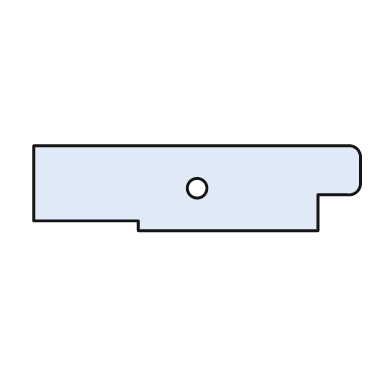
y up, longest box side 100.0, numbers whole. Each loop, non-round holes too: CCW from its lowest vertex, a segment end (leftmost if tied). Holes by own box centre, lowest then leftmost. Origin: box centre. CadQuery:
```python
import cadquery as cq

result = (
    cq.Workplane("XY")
    .moveTo(-18.0, -13.0)
    .lineTo(37.0, -13.0)
    .lineTo(37.0, -2.0)
    .lineTo(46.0, -2.0)
    .threePointArc((49.0, -1.0), (50.0, 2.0))
    .lineTo(50.0, 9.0)
    .threePointArc((49.0, 12.0), (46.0, 13.0))
    .lineTo(-50.0, 13.0)
    .lineTo(-50.0, -10.0)
    .lineTo(-18.0, -10.0)
    .close()
    .moveTo(0.0, 0.0)
    .circle(3.0)
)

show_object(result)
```